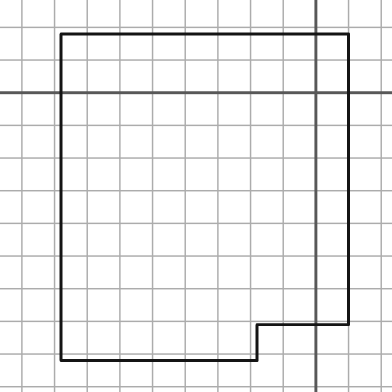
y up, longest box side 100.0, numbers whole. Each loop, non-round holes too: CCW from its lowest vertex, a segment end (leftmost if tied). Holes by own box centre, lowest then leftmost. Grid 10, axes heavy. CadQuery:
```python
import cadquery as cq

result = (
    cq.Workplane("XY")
    .moveTo(-78.0, -82.0)
    .lineTo(-18.0, -82.0)
    .lineTo(-18.0, -71.0)
    .lineTo(10.0, -71.0)
    .lineTo(10.0, 18.0)
    .lineTo(-78.0, 18.0)
    .close()
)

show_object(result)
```